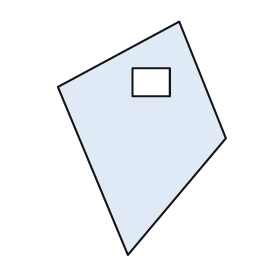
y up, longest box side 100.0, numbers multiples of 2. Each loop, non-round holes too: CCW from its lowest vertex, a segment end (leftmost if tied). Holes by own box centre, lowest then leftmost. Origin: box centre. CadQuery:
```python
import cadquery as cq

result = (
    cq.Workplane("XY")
    .moveTo(-6.0, -50.0)
    .lineTo(36.0, 0.0)
    .lineTo(16.0, 50.0)
    .lineTo(-36.0, 22.0)
    .close()
    .moveTo(-4.0, 18.0)
    .lineTo(12.0, 18.0)
    .lineTo(12.0, 30.0)
    .lineTo(-4.0, 30.0)
    .close()
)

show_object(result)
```